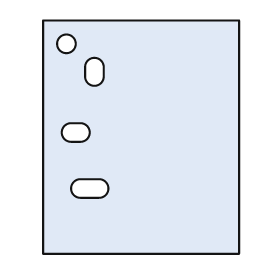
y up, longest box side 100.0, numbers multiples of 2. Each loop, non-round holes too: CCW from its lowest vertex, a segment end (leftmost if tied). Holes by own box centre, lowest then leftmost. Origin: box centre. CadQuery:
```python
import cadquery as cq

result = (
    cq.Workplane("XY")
    .moveTo(-42.0, -50.0)
    .lineTo(42.0, -50.0)
    .lineTo(42.0, 50.0)
    .lineTo(-42.0, 50.0)
    .close()
    .moveTo(-26.0, -26.0)
    .lineTo(-18.0, -26.0)
    .threePointArc((-14.0, -22.0), (-18.0, -18.0))
    .lineTo(-26.0, -18.0)
    .threePointArc((-30.0, -22.0), (-26.0, -26.0))
    .close()
    .moveTo(-30.0, -2.0)
    .lineTo(-26.0, -2.0)
    .threePointArc((-22.0, 2.0), (-26.0, 6.0))
    .lineTo(-30.0, 6.0)
    .threePointArc((-34.0, 2.0), (-30.0, -2.0))
    .close()
    .moveTo(-24.0, 26.0)
    .threePointArc((-20.0, 22.0), (-16.0, 26.0))
    .lineTo(-16.0, 30.0)
    .threePointArc((-20.0, 34.0), (-24.0, 30.0))
    .close()
    .moveTo(-32.0, 40.0)
    .circle(4.0)
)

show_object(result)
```